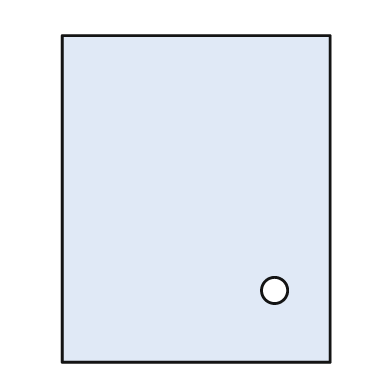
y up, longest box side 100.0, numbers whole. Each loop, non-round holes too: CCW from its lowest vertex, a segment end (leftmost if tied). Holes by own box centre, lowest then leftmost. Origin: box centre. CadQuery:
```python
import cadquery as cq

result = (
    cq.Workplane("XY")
    .moveTo(-41.0, -50.0)
    .lineTo(41.0, -50.0)
    .lineTo(41.0, 50.0)
    .lineTo(-41.0, 50.0)
    .close()
    .moveTo(24.0, -28.0)
    .circle(4.0)
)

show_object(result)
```